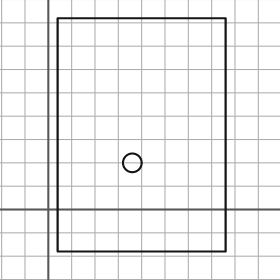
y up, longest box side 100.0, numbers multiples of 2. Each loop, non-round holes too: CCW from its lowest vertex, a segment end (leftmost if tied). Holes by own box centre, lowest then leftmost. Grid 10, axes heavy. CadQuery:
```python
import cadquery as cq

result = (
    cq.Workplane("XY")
    .moveTo(4.0, -18.0)
    .lineTo(76.0, -18.0)
    .lineTo(76.0, 82.0)
    .lineTo(4.0, 82.0)
    .close()
    .moveTo(36.0, 20.0)
    .circle(4.0)
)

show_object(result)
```